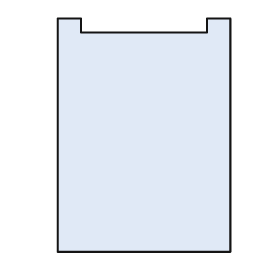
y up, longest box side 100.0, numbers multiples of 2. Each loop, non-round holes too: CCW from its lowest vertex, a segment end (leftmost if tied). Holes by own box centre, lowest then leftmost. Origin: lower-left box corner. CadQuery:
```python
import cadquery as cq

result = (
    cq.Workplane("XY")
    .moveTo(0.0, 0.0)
    .lineTo(74.0, 0.0)
    .lineTo(74.0, 100.0)
    .lineTo(64.0, 100.0)
    .lineTo(64.0, 94.0)
    .lineTo(10.0, 94.0)
    .lineTo(10.0, 100.0)
    .lineTo(0.0, 100.0)
    .close()
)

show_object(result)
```